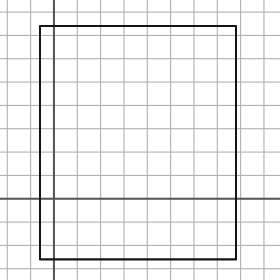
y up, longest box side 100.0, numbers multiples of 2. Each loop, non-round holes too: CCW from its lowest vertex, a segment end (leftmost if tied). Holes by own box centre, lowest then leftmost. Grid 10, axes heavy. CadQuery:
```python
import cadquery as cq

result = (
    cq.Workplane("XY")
    .moveTo(-6.0, -26.0)
    .lineTo(78.0, -26.0)
    .lineTo(78.0, 74.0)
    .lineTo(-6.0, 74.0)
    .close()
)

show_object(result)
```